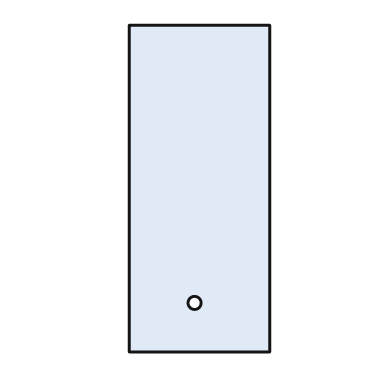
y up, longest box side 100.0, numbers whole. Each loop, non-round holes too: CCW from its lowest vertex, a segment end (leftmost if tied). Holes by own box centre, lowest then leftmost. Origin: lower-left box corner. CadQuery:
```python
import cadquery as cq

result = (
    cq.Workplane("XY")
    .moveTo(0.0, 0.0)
    .lineTo(43.0, 0.0)
    .lineTo(43.0, 100.0)
    .lineTo(0.0, 100.0)
    .close()
    .moveTo(20.0, 15.0)
    .circle(2.0)
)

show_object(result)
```